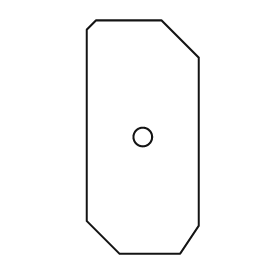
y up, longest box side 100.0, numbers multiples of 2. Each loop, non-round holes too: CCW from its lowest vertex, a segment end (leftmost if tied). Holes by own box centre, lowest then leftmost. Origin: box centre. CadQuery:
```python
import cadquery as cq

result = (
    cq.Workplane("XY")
    .moveTo(-10.0, -50.0)
    .lineTo(16.0, -50.0)
    .lineTo(24.0, -38.0)
    .lineTo(24.0, 34.0)
    .lineTo(8.0, 50.0)
    .lineTo(-20.0, 50.0)
    .lineTo(-24.0, 46.0)
    .lineTo(-24.0, -36.0)
    .close()
    .moveTo(0.0, 0.0)
    .circle(4.0)
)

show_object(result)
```